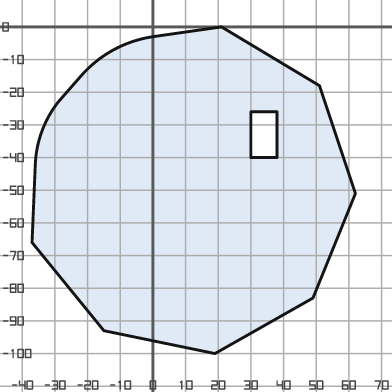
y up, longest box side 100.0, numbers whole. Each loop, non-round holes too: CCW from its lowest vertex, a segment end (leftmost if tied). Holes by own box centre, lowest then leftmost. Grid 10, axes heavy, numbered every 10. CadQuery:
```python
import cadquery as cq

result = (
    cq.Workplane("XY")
    .moveTo(19.0, -100.0)
    .lineTo(49.0, -83.0)
    .lineTo(62.0, -51.0)
    .lineTo(51.0, -18.0)
    .lineTo(21.0, 0.0)
    .lineTo(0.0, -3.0)
    .threePointArc((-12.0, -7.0), (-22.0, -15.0))
    .lineTo(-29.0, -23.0)
    .threePointArc((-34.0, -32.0), (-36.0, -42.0))
    .lineTo(-37.0, -66.0)
    .lineTo(-15.0, -93.0)
    .close()
    .moveTo(30.0, -40.0)
    .lineTo(38.0, -40.0)
    .lineTo(38.0, -26.0)
    .lineTo(30.0, -26.0)
    .close()
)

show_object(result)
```